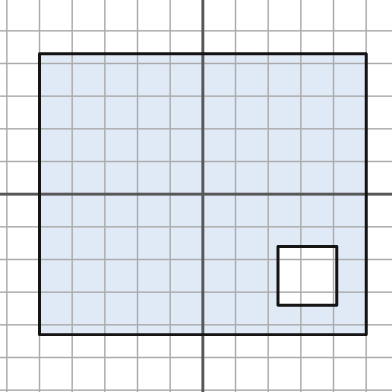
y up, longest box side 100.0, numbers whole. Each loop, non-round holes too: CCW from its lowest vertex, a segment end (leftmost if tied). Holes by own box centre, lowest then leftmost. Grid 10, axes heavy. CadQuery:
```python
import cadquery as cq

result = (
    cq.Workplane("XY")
    .moveTo(-50.0, -43.0)
    .lineTo(50.0, -43.0)
    .lineTo(50.0, 43.0)
    .lineTo(-50.0, 43.0)
    .close()
    .moveTo(23.0, -34.0)
    .lineTo(41.0, -34.0)
    .lineTo(41.0, -16.0)
    .lineTo(23.0, -16.0)
    .close()
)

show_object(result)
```